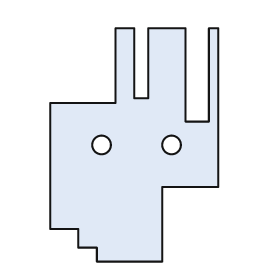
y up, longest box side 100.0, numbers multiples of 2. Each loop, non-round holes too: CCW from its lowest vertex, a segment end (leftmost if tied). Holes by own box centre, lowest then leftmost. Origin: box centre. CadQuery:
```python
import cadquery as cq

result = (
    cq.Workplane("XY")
    .moveTo(-16.0, -50.0)
    .lineTo(12.0, -50.0)
    .lineTo(12.0, -18.0)
    .lineTo(36.0, -18.0)
    .lineTo(36.0, 50.0)
    .lineTo(32.0, 50.0)
    .lineTo(32.0, 10.0)
    .lineTo(22.0, 10.0)
    .lineTo(22.0, 50.0)
    .lineTo(6.0, 50.0)
    .lineTo(6.0, 20.0)
    .lineTo(0.0, 20.0)
    .lineTo(0.0, 50.0)
    .lineTo(-8.0, 50.0)
    .lineTo(-8.0, 18.0)
    .lineTo(-36.0, 18.0)
    .lineTo(-36.0, -36.0)
    .lineTo(-24.0, -36.0)
    .lineTo(-24.0, -44.0)
    .lineTo(-16.0, -44.0)
    .close()
    .moveTo(-14.0, 0.0)
    .circle(4.0)
    .moveTo(16.0, 0.0)
    .circle(4.0)
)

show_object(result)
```